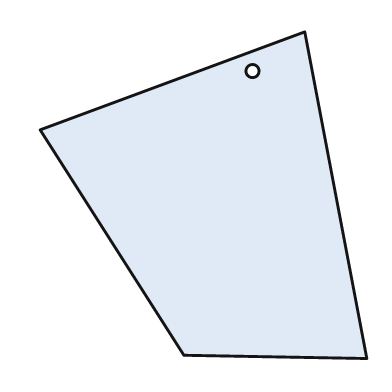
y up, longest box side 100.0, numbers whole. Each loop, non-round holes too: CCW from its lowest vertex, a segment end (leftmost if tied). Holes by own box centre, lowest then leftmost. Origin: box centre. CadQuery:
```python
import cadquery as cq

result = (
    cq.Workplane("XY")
    .moveTo(50.0, -50.0)
    .lineTo(31.0, 50.0)
    .lineTo(-50.0, 20.0)
    .lineTo(-6.0, -49.0)
    .close()
    .moveTo(15.0, 38.0)
    .circle(2.0)
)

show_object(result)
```